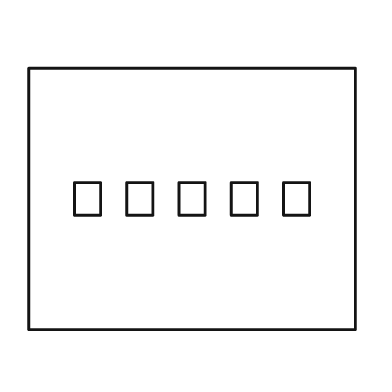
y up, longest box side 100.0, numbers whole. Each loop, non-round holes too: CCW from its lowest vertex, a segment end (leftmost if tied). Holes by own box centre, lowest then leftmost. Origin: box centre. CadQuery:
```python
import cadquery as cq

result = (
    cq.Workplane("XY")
    .moveTo(-50.0, -40.0)
    .lineTo(50.0, -40.0)
    .lineTo(50.0, 40.0)
    .lineTo(-50.0, 40.0)
    .close()
    .moveTo(-36.0, -5.0)
    .lineTo(-28.0, -5.0)
    .lineTo(-28.0, 5.0)
    .lineTo(-36.0, 5.0)
    .close()
    .moveTo(-20.0, -5.0)
    .lineTo(-12.0, -5.0)
    .lineTo(-12.0, 5.0)
    .lineTo(-20.0, 5.0)
    .close()
    .moveTo(-4.0, -5.0)
    .lineTo(4.0, -5.0)
    .lineTo(4.0, 5.0)
    .lineTo(-4.0, 5.0)
    .close()
    .moveTo(12.0, -5.0)
    .lineTo(20.0, -5.0)
    .lineTo(20.0, 5.0)
    .lineTo(12.0, 5.0)
    .close()
    .moveTo(28.0, -5.0)
    .lineTo(36.0, -5.0)
    .lineTo(36.0, 5.0)
    .lineTo(28.0, 5.0)
    .close()
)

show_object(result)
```